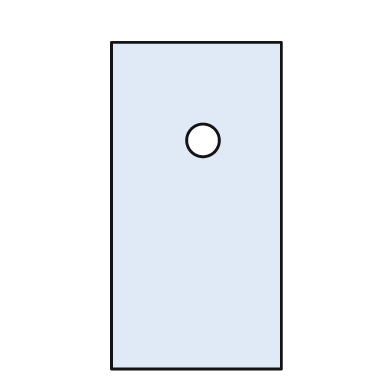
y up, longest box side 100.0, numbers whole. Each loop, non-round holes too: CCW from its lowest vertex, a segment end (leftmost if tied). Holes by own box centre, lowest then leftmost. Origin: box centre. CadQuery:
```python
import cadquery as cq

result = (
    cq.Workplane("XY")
    .moveTo(-26.0, -50.0)
    .lineTo(26.0, -50.0)
    .lineTo(26.0, 50.0)
    .lineTo(-26.0, 50.0)
    .close()
    .moveTo(2.0, 20.0)
    .circle(5.0)
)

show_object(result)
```